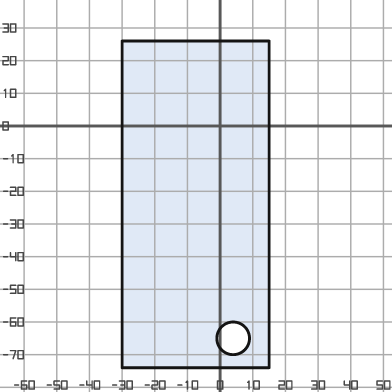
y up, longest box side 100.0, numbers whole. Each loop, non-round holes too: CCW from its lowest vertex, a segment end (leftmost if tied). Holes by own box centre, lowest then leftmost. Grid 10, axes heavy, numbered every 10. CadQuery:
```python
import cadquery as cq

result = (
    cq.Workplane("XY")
    .moveTo(-30.0, -74.0)
    .lineTo(15.0, -74.0)
    .lineTo(15.0, 26.0)
    .lineTo(-30.0, 26.0)
    .close()
    .moveTo(4.0, -65.0)
    .circle(5.0)
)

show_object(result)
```